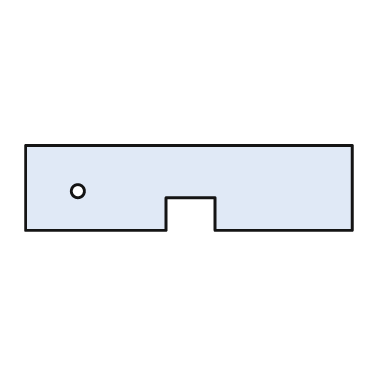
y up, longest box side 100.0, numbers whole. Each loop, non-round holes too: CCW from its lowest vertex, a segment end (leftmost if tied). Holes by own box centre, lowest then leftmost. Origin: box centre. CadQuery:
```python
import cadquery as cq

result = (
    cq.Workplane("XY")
    .moveTo(-50.0, -13.0)
    .lineTo(-7.0, -13.0)
    .lineTo(-7.0, -3.0)
    .lineTo(8.0, -3.0)
    .lineTo(8.0, -13.0)
    .lineTo(50.0, -13.0)
    .lineTo(50.0, 13.0)
    .lineTo(-50.0, 13.0)
    .close()
    .moveTo(-34.0, -1.0)
    .circle(2.0)
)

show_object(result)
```